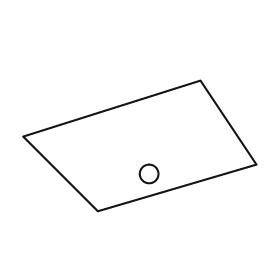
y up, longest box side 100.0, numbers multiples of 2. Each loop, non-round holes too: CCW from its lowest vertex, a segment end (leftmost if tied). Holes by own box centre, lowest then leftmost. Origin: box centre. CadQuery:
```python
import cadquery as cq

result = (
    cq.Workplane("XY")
    .moveTo(-18.0, -28.0)
    .lineTo(50.0, -8.0)
    .lineTo(26.0, 28.0)
    .lineTo(-50.0, 4.0)
    .close()
    .moveTo(4.0, -12.0)
    .circle(4.0)
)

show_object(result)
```